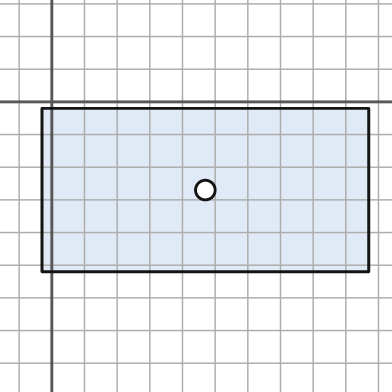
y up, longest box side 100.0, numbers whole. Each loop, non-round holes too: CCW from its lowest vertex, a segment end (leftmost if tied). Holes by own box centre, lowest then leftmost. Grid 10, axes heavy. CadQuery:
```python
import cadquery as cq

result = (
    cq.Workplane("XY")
    .moveTo(-3.0, -52.0)
    .lineTo(97.0, -52.0)
    .lineTo(97.0, -2.0)
    .lineTo(-3.0, -2.0)
    .close()
    .moveTo(47.0, -27.0)
    .circle(3.0)
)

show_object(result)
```